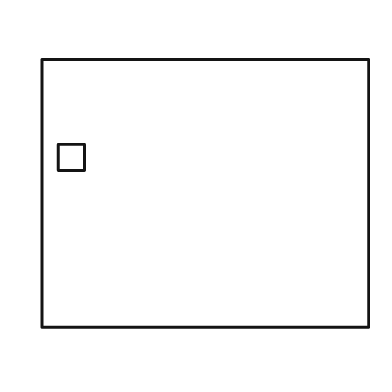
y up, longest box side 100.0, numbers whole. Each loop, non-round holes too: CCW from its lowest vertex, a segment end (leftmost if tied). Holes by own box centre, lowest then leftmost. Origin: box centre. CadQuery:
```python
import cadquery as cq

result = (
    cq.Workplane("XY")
    .moveTo(-50.0, -41.0)
    .lineTo(50.0, -41.0)
    .lineTo(50.0, 41.0)
    .lineTo(-50.0, 41.0)
    .close()
    .moveTo(-45.0, 7.0)
    .lineTo(-37.0, 7.0)
    .lineTo(-37.0, 15.0)
    .lineTo(-45.0, 15.0)
    .close()
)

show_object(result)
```